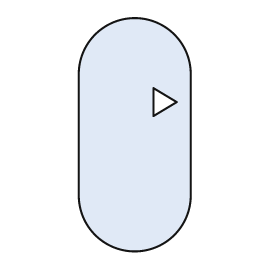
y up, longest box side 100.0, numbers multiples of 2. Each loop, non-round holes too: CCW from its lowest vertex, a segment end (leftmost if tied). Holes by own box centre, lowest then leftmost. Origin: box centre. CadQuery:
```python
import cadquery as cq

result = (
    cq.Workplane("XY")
    .moveTo(-24.0, -26.0)
    .threePointArc((0.0, -50.0), (24.0, -26.0))
    .lineTo(24.0, 26.0)
    .threePointArc((0.0, 50.0), (-24.0, 26.0))
    .close()
    .moveTo(8.0, 8.0)
    .lineTo(18.0, 14.0)
    .lineTo(8.0, 20.0)
    .close()
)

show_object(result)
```